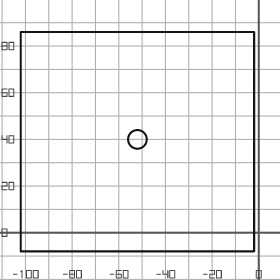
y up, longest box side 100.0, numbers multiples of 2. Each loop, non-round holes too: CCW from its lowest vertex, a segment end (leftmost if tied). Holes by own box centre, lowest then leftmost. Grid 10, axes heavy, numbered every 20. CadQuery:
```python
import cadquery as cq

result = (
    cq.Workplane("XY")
    .moveTo(-102.0, -8.0)
    .lineTo(-2.0, -8.0)
    .lineTo(-2.0, 86.0)
    .lineTo(-102.0, 86.0)
    .close()
    .moveTo(-52.0, 40.0)
    .circle(4.0)
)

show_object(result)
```